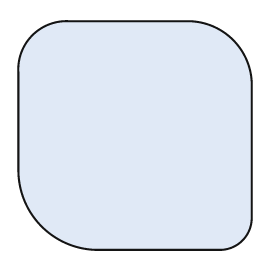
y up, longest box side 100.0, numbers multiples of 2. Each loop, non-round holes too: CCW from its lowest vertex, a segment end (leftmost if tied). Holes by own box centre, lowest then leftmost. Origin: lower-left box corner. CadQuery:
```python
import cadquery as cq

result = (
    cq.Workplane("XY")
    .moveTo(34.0, 0.0)
    .lineTo(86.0, 0.0)
    .threePointArc((96.0, 4.0), (100.0, 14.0))
    .lineTo(100.0, 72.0)
    .threePointArc((92.0, 90.0), (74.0, 98.0))
    .lineTo(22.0, 98.0)
    .threePointArc((6.0, 92.0), (0.0, 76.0))
    .lineTo(0.0, 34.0)
    .threePointArc((10.0, 10.0), (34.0, 0.0))
    .close()
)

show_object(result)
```